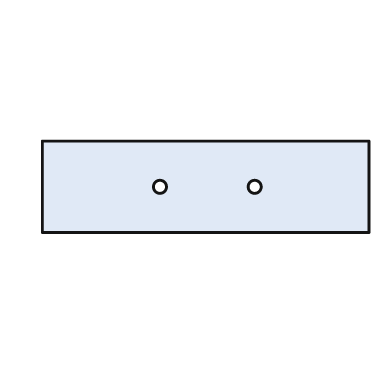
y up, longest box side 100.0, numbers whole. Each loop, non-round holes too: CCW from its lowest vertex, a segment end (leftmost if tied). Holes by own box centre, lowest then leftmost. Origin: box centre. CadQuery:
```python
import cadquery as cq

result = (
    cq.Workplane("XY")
    .moveTo(-50.0, -14.0)
    .lineTo(50.0, -14.0)
    .lineTo(50.0, 14.0)
    .lineTo(-50.0, 14.0)
    .close()
    .moveTo(-14.0, 0.0)
    .circle(2.0)
    .moveTo(15.0, 0.0)
    .circle(2.0)
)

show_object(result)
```